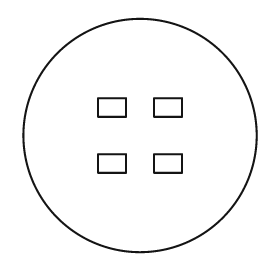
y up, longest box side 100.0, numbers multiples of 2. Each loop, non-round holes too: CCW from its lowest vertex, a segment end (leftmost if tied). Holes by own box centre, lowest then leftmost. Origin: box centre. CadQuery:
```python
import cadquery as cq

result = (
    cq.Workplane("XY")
    .moveTo(0.0, 0.0)
    .circle(50.0)
    .moveTo(-18.0, -16.0)
    .lineTo(-6.0, -16.0)
    .lineTo(-6.0, -8.0)
    .lineTo(-18.0, -8.0)
    .close()
    .moveTo(6.0, -16.0)
    .lineTo(18.0, -16.0)
    .lineTo(18.0, -8.0)
    .lineTo(6.0, -8.0)
    .close()
    .moveTo(-18.0, 8.0)
    .lineTo(-6.0, 8.0)
    .lineTo(-6.0, 16.0)
    .lineTo(-18.0, 16.0)
    .close()
    .moveTo(6.0, 8.0)
    .lineTo(18.0, 8.0)
    .lineTo(18.0, 16.0)
    .lineTo(6.0, 16.0)
    .close()
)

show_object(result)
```